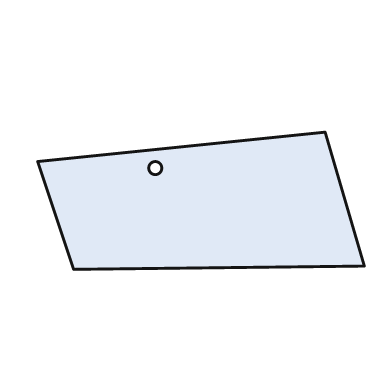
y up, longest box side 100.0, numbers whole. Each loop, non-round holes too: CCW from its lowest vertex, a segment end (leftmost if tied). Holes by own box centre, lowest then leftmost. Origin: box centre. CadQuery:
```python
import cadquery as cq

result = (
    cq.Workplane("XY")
    .moveTo(-39.0, -21.0)
    .lineTo(50.0, -20.0)
    .lineTo(38.0, 21.0)
    .lineTo(-50.0, 12.0)
    .close()
    .moveTo(-14.0, 10.0)
    .circle(2.0)
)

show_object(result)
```